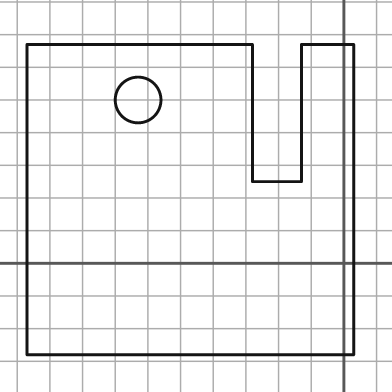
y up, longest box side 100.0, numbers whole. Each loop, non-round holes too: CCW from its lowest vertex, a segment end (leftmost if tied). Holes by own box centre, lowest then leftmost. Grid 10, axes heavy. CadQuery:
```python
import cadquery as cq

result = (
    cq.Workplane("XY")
    .moveTo(-97.0, -28.0)
    .lineTo(3.0, -28.0)
    .lineTo(3.0, 67.0)
    .lineTo(-13.0, 67.0)
    .lineTo(-13.0, 25.0)
    .lineTo(-28.0, 25.0)
    .lineTo(-28.0, 67.0)
    .lineTo(-97.0, 67.0)
    .close()
    .moveTo(-63.0, 50.0)
    .circle(7.0)
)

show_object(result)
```